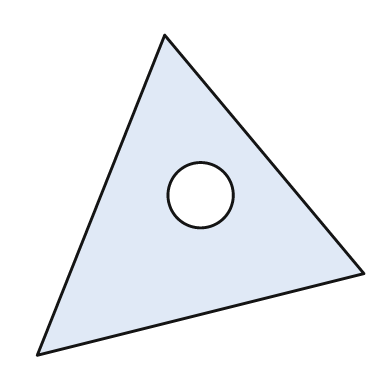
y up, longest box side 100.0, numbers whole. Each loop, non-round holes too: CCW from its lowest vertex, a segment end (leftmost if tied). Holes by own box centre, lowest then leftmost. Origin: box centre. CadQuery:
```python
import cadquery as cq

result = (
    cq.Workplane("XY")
    .moveTo(-50.0, -49.0)
    .lineTo(50.0, -24.0)
    .lineTo(-11.0, 49.0)
    .close()
    .moveTo(0.0, 0.0)
    .circle(10.0)
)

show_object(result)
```